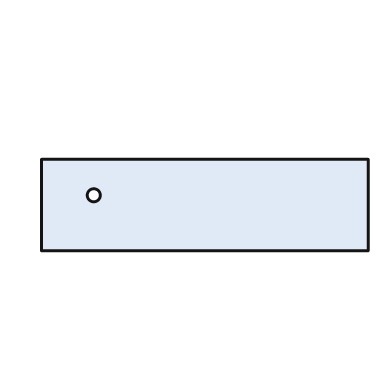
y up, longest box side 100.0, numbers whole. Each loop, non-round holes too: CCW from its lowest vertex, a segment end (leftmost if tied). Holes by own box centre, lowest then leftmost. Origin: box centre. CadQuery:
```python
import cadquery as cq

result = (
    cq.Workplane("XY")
    .moveTo(-50.0, -14.0)
    .lineTo(50.0, -14.0)
    .lineTo(50.0, 14.0)
    .lineTo(-50.0, 14.0)
    .close()
    .moveTo(-34.0, 3.0)
    .circle(2.0)
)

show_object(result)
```